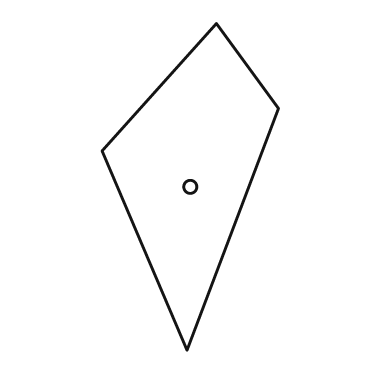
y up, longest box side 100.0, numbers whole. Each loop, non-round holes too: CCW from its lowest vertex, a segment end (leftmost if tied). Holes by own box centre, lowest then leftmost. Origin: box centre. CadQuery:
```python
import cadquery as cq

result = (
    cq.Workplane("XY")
    .moveTo(-1.0, -50.0)
    .lineTo(27.0, 24.0)
    .lineTo(8.0, 50.0)
    .lineTo(-27.0, 11.0)
    .close()
    .moveTo(0.0, 0.0)
    .circle(2.0)
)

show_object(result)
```